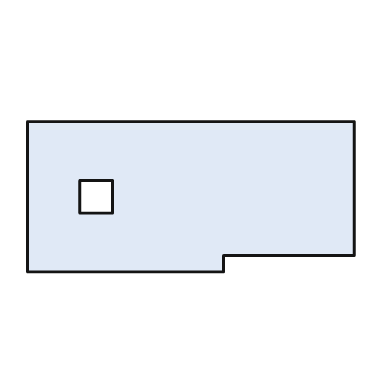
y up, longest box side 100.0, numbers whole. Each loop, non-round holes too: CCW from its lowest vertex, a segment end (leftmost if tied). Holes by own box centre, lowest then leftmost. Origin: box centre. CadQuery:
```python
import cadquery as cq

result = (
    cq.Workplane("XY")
    .moveTo(-50.0, -23.0)
    .lineTo(10.0, -23.0)
    .lineTo(10.0, -18.0)
    .lineTo(50.0, -18.0)
    .lineTo(50.0, 23.0)
    .lineTo(-50.0, 23.0)
    .close()
    .moveTo(-34.0, -5.0)
    .lineTo(-24.0, -5.0)
    .lineTo(-24.0, 5.0)
    .lineTo(-34.0, 5.0)
    .close()
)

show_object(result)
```